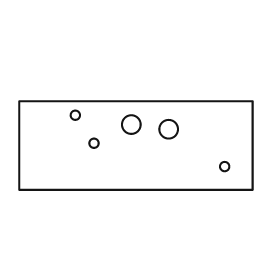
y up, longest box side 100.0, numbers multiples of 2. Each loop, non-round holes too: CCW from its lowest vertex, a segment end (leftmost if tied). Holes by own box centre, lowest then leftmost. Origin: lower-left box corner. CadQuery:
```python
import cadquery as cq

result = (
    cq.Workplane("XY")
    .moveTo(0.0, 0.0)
    .lineTo(100.0, 0.0)
    .lineTo(100.0, 38.0)
    .lineTo(0.0, 38.0)
    .close()
    .moveTo(88.0, 10.0)
    .circle(2.0)
    .moveTo(32.0, 20.0)
    .circle(2.0)
    .moveTo(64.0, 26.0)
    .circle(4.0)
    .moveTo(48.0, 28.0)
    .circle(4.0)
    .moveTo(24.0, 32.0)
    .circle(2.0)
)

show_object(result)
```